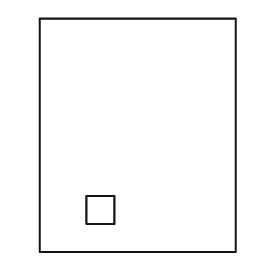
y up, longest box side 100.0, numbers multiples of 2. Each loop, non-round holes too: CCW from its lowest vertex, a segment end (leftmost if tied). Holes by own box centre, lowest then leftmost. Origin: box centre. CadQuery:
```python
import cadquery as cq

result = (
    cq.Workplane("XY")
    .moveTo(-42.0, -50.0)
    .lineTo(42.0, -50.0)
    .lineTo(42.0, 50.0)
    .lineTo(-42.0, 50.0)
    .close()
    .moveTo(-22.0, -38.0)
    .lineTo(-10.0, -38.0)
    .lineTo(-10.0, -26.0)
    .lineTo(-22.0, -26.0)
    .close()
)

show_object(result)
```